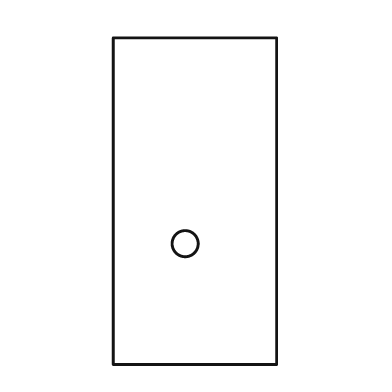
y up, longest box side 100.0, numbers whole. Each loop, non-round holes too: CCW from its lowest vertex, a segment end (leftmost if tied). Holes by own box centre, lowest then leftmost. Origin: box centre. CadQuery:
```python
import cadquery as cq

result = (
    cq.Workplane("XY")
    .moveTo(-25.0, -50.0)
    .lineTo(25.0, -50.0)
    .lineTo(25.0, 50.0)
    .lineTo(-25.0, 50.0)
    .close()
    .moveTo(-3.0, -13.0)
    .circle(4.0)
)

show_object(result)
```